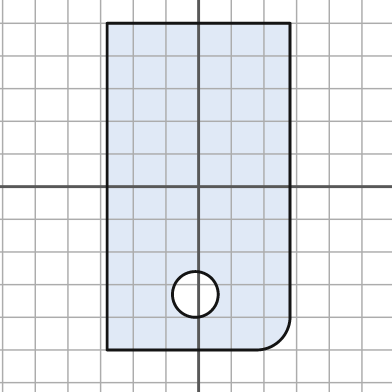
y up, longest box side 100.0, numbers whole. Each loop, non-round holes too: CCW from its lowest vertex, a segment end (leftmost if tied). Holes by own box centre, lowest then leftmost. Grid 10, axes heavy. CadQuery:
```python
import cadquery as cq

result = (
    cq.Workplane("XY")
    .moveTo(-28.0, -50.0)
    .lineTo(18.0, -50.0)
    .threePointArc((25.0, -47.0), (28.0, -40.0))
    .lineTo(28.0, 50.0)
    .lineTo(-28.0, 50.0)
    .close()
    .moveTo(-1.0, -33.0)
    .circle(7.0)
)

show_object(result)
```